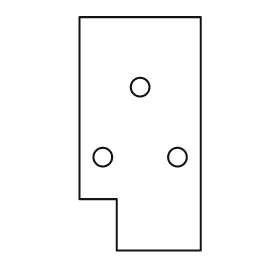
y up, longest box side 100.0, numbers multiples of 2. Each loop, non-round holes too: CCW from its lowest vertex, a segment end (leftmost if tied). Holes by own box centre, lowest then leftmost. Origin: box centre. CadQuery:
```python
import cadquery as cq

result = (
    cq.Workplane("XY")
    .moveTo(-10.0, -50.0)
    .lineTo(26.0, -50.0)
    .lineTo(26.0, 50.0)
    .lineTo(-26.0, 50.0)
    .lineTo(-26.0, -28.0)
    .lineTo(-10.0, -28.0)
    .close()
    .moveTo(-16.0, -10.0)
    .circle(4.0)
    .moveTo(16.0, -10.0)
    .circle(4.0)
    .moveTo(0.0, 20.0)
    .circle(4.0)
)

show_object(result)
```